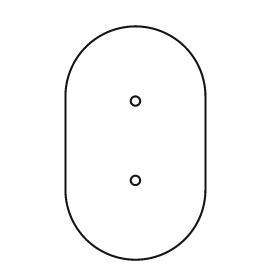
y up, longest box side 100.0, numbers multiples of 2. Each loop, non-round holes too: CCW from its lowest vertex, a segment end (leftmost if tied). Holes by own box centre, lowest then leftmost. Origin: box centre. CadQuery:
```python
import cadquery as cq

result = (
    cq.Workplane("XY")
    .moveTo(-30.0, -20.0)
    .threePointArc((0.0, -50.0), (30.0, -20.0))
    .lineTo(30.0, 20.0)
    .threePointArc((0.0, 50.0), (-30.0, 20.0))
    .close()
    .moveTo(0.0, -16.0)
    .circle(2.0)
    .moveTo(0.0, 18.0)
    .circle(2.0)
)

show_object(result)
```